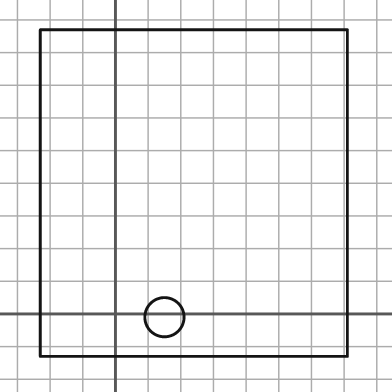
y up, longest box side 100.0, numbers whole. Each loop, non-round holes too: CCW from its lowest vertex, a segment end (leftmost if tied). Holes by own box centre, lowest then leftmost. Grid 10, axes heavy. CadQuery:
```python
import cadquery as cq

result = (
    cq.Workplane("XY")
    .moveTo(-23.0, -13.0)
    .lineTo(71.0, -13.0)
    .lineTo(71.0, 87.0)
    .lineTo(-23.0, 87.0)
    .close()
    .moveTo(15.0, -1.0)
    .circle(6.0)
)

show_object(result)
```